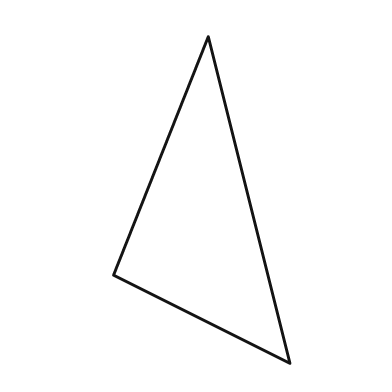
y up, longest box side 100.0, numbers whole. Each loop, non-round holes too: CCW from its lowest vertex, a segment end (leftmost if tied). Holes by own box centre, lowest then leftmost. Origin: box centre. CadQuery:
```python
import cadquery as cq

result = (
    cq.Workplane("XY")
    .moveTo(27.0, -50.0)
    .lineTo(2.0, 50.0)
    .lineTo(-27.0, -23.0)
    .close()
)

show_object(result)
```